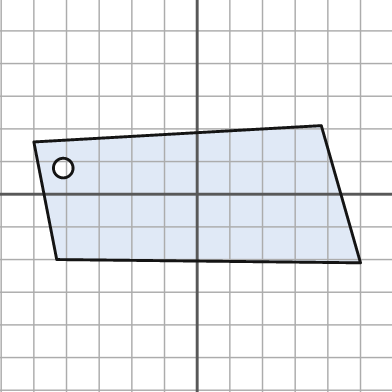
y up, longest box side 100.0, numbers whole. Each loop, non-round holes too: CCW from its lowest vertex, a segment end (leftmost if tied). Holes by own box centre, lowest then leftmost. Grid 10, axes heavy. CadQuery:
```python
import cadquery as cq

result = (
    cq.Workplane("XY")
    .moveTo(50.0, -21.0)
    .lineTo(38.0, 21.0)
    .lineTo(-50.0, 16.0)
    .lineTo(-43.0, -20.0)
    .close()
    .moveTo(-41.0, 8.0)
    .circle(3.0)
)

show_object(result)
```